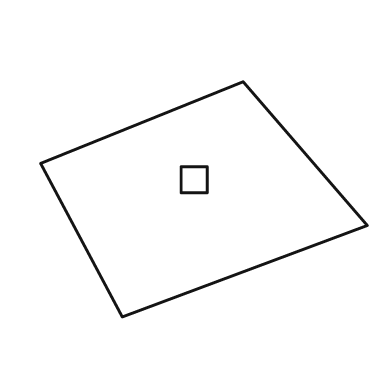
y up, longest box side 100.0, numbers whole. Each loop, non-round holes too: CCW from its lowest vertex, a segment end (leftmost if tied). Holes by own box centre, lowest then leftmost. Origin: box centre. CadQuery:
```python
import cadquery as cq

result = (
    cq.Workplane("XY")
    .moveTo(-25.0, -36.0)
    .lineTo(50.0, -8.0)
    .lineTo(12.0, 36.0)
    .lineTo(-50.0, 11.0)
    .close()
    .moveTo(-7.0, 2.0)
    .lineTo(1.0, 2.0)
    .lineTo(1.0, 10.0)
    .lineTo(-7.0, 10.0)
    .close()
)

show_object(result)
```